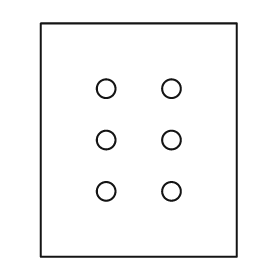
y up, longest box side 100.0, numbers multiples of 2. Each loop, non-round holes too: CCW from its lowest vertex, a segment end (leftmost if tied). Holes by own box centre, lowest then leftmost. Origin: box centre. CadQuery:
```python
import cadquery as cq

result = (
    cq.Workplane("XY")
    .moveTo(-42.0, -50.0)
    .lineTo(42.0, -50.0)
    .lineTo(42.0, 50.0)
    .lineTo(-42.0, 50.0)
    .close()
    .moveTo(-14.0, -22.0)
    .circle(4.0)
    .moveTo(14.0, -22.0)
    .circle(4.0)
    .moveTo(-14.0, 0.0)
    .circle(4.0)
    .moveTo(14.0, 0.0)
    .circle(4.0)
    .moveTo(-14.0, 22.0)
    .circle(4.0)
    .moveTo(14.0, 22.0)
    .circle(4.0)
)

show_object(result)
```